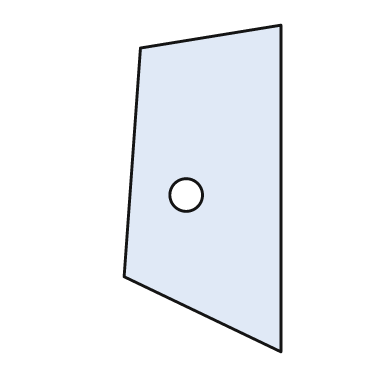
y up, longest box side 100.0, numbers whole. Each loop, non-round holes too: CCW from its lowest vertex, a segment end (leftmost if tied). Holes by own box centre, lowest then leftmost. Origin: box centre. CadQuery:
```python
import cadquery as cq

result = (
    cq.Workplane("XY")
    .moveTo(24.0, -50.0)
    .lineTo(24.0, 50.0)
    .lineTo(-19.0, 43.0)
    .lineTo(-24.0, -27.0)
    .close()
    .moveTo(-5.0, -2.0)
    .circle(5.0)
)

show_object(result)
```